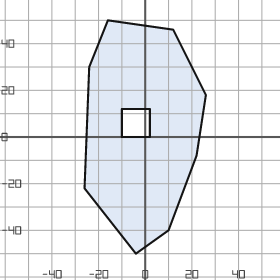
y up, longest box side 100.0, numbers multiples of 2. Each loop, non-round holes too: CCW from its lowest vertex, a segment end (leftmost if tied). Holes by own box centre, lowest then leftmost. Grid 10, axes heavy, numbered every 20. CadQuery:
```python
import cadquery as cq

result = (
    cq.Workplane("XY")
    .moveTo(-4.0, -50.0)
    .lineTo(10.0, -40.0)
    .lineTo(22.0, -8.0)
    .lineTo(26.0, 18.0)
    .lineTo(12.0, 46.0)
    .lineTo(-16.0, 50.0)
    .lineTo(-24.0, 30.0)
    .lineTo(-26.0, -22.0)
    .close()
    .moveTo(-10.0, 0.0)
    .lineTo(2.0, 0.0)
    .lineTo(2.0, 12.0)
    .lineTo(-10.0, 12.0)
    .close()
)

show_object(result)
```